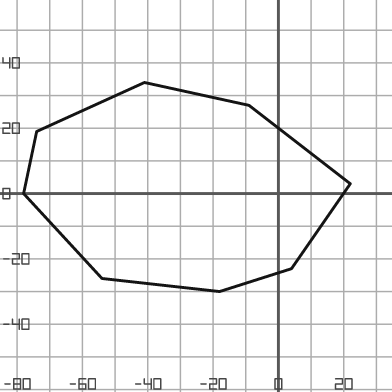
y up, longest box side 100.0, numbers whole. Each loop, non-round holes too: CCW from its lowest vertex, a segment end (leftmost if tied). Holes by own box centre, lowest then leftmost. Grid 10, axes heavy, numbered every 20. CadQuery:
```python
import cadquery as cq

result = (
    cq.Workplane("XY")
    .moveTo(-18.0, -30.0)
    .lineTo(4.0, -23.0)
    .lineTo(22.0, 3.0)
    .lineTo(-9.0, 27.0)
    .lineTo(-41.0, 34.0)
    .lineTo(-74.0, 19.0)
    .lineTo(-78.0, 0.0)
    .lineTo(-54.0, -26.0)
    .close()
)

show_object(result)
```